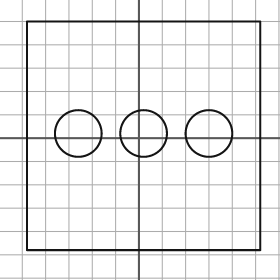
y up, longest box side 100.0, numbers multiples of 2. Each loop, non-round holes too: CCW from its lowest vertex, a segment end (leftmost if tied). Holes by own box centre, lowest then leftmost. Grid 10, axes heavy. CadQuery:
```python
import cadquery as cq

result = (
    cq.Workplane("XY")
    .moveTo(-48.0, -48.0)
    .lineTo(52.0, -48.0)
    .lineTo(52.0, 50.0)
    .lineTo(-48.0, 50.0)
    .close()
    .moveTo(-26.0, 2.0)
    .circle(10.0)
    .moveTo(2.0, 2.0)
    .circle(10.0)
    .moveTo(30.0, 2.0)
    .circle(10.0)
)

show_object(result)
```